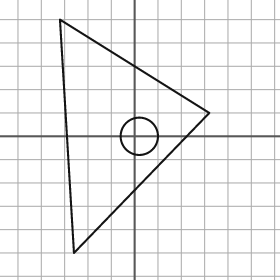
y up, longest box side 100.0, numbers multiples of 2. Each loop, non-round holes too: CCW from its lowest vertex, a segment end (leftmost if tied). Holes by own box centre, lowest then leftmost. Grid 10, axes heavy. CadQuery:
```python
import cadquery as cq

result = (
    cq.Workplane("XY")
    .moveTo(-26.0, -50.0)
    .lineTo(32.0, 10.0)
    .lineTo(-32.0, 50.0)
    .close()
    .moveTo(2.0, 0.0)
    .circle(8.0)
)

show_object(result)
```